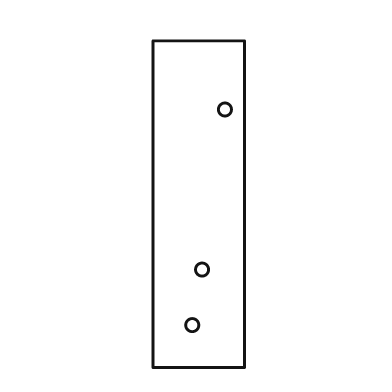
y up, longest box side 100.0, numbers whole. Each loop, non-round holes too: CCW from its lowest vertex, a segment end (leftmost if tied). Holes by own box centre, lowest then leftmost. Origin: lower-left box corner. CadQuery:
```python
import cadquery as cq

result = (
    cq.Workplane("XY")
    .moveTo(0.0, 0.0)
    .lineTo(28.0, 0.0)
    .lineTo(28.0, 100.0)
    .lineTo(0.0, 100.0)
    .close()
    .moveTo(12.0, 13.0)
    .circle(2.0)
    .moveTo(15.0, 30.0)
    .circle(2.0)
    .moveTo(22.0, 79.0)
    .circle(2.0)
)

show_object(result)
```